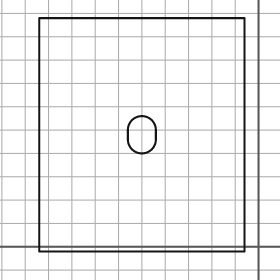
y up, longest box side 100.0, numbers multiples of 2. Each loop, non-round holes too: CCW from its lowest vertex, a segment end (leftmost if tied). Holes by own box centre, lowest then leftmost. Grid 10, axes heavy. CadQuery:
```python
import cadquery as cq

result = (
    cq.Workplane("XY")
    .moveTo(-94.0, -2.0)
    .lineTo(-6.0, -2.0)
    .lineTo(-6.0, 98.0)
    .lineTo(-94.0, 98.0)
    .close()
    .moveTo(-56.0, 46.0)
    .threePointArc((-50.0, 40.0), (-44.0, 46.0))
    .lineTo(-44.0, 50.0)
    .threePointArc((-50.0, 56.0), (-56.0, 50.0))
    .close()
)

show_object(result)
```